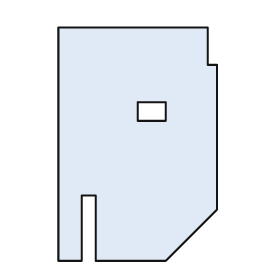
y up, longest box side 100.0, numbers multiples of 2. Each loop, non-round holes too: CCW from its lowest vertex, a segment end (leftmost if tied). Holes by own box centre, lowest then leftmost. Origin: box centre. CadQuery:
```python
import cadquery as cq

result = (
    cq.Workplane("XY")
    .moveTo(-34.0, -50.0)
    .lineTo(-24.0, -50.0)
    .lineTo(-24.0, -22.0)
    .lineTo(-18.0, -22.0)
    .lineTo(-18.0, -50.0)
    .lineTo(12.0, -50.0)
    .lineTo(34.0, -28.0)
    .lineTo(34.0, 34.0)
    .lineTo(30.0, 34.0)
    .lineTo(30.0, 50.0)
    .lineTo(-34.0, 50.0)
    .close()
    .moveTo(0.0, 10.0)
    .lineTo(12.0, 10.0)
    .lineTo(12.0, 18.0)
    .lineTo(0.0, 18.0)
    .close()
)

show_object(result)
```